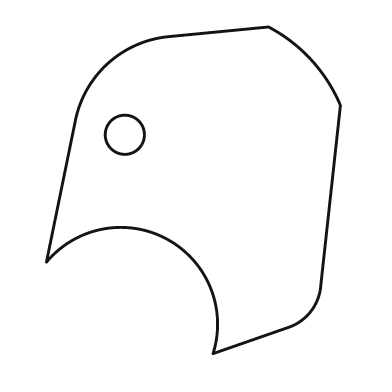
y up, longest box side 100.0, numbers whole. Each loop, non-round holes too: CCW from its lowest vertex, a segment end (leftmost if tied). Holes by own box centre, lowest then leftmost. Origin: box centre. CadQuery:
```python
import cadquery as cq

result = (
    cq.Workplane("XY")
    .moveTo(6.0, -50.0)
    .lineTo(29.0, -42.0)
    .threePointArc((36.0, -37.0), (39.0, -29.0))
    .lineTo(45.0, 26.0)
    .threePointArc((36.0, 40.0), (23.0, 50.0))
    .lineTo(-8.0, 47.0)
    .threePointArc((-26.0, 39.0), (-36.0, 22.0))
    .lineTo(-45.0, -22.0)
    .threePointArc((-8.0, -15.0), (6.0, -50.0))
    .close()
    .moveTo(-21.0, 17.0)
    .circle(6.0)
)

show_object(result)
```